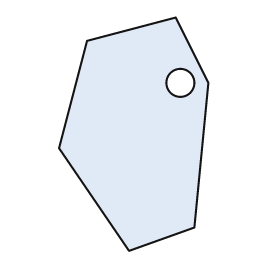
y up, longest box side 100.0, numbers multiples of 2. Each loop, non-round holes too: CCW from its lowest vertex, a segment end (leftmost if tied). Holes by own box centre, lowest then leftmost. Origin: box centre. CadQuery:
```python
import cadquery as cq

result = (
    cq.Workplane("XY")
    .moveTo(-2.0, -50.0)
    .lineTo(26.0, -40.0)
    .lineTo(32.0, 22.0)
    .lineTo(18.0, 50.0)
    .lineTo(-20.0, 40.0)
    .lineTo(-32.0, -6.0)
    .close()
    .moveTo(20.0, 22.0)
    .circle(6.0)
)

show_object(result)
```